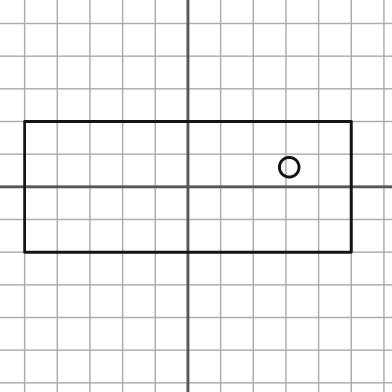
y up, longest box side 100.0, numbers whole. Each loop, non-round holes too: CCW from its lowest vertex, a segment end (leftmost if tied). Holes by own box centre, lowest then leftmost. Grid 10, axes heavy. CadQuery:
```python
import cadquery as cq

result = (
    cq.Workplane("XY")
    .moveTo(-50.0, -20.0)
    .lineTo(50.0, -20.0)
    .lineTo(50.0, 20.0)
    .lineTo(-50.0, 20.0)
    .close()
    .moveTo(31.0, 6.0)
    .circle(3.0)
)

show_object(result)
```